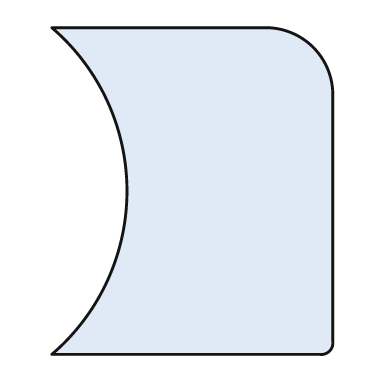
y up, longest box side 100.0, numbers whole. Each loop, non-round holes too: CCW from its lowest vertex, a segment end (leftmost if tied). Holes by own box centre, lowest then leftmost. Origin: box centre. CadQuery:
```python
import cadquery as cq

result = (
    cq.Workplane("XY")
    .moveTo(-43.0, -50.0)
    .lineTo(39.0, -50.0)
    .threePointArc((42.0, -49.0), (43.0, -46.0))
    .lineTo(43.0, 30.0)
    .threePointArc((37.0, 44.0), (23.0, 50.0))
    .lineTo(-43.0, 50.0)
    .threePointArc((-20.0, 0.0), (-43.0, -50.0))
    .close()
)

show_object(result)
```